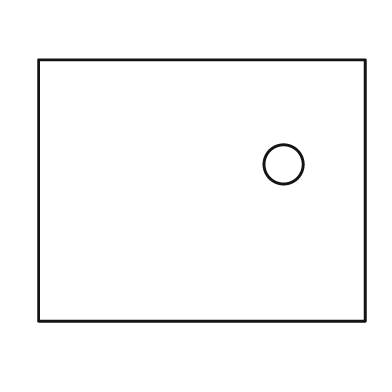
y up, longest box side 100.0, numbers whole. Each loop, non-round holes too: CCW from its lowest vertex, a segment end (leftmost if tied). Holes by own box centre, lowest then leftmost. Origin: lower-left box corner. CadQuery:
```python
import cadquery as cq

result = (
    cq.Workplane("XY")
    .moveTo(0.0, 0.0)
    .lineTo(100.0, 0.0)
    .lineTo(100.0, 80.0)
    .lineTo(0.0, 80.0)
    .close()
    .moveTo(75.0, 48.0)
    .circle(6.0)
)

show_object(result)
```